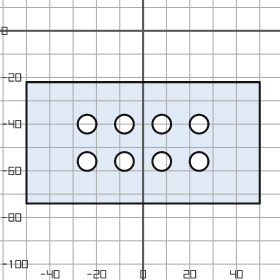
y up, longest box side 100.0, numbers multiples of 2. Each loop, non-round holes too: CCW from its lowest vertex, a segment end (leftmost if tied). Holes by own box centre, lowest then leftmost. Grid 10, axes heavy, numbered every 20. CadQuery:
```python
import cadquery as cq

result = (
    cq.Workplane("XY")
    .moveTo(-50.0, -74.0)
    .lineTo(50.0, -74.0)
    .lineTo(50.0, -22.0)
    .lineTo(-50.0, -22.0)
    .close()
    .moveTo(-24.0, -56.0)
    .circle(4.0)
    .moveTo(-8.0, -56.0)
    .circle(4.0)
    .moveTo(8.0, -56.0)
    .circle(4.0)
    .moveTo(24.0, -56.0)
    .circle(4.0)
    .moveTo(-24.0, -40.0)
    .circle(4.0)
    .moveTo(-8.0, -40.0)
    .circle(4.0)
    .moveTo(8.0, -40.0)
    .circle(4.0)
    .moveTo(24.0, -40.0)
    .circle(4.0)
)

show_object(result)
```